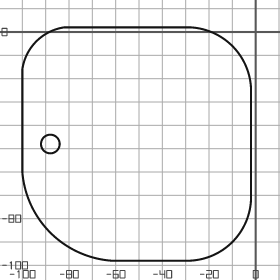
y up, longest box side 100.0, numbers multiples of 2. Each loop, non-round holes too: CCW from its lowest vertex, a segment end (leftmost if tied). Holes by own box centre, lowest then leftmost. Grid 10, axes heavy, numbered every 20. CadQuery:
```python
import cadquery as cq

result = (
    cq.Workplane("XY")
    .moveTo(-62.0, -98.0)
    .lineTo(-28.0, -98.0)
    .threePointArc((-10.0, -90.0), (-2.0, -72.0))
    .lineTo(-2.0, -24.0)
    .threePointArc((-10.0, -6.0), (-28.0, 2.0))
    .lineTo(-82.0, 2.0)
    .threePointArc((-94.0, -4.0), (-100.0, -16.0))
    .lineTo(-100.0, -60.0)
    .threePointArc((-88.0, -86.0), (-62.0, -98.0))
    .close()
    .moveTo(-88.0, -48.0)
    .circle(4.0)
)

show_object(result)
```